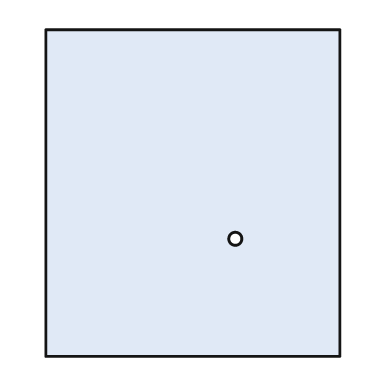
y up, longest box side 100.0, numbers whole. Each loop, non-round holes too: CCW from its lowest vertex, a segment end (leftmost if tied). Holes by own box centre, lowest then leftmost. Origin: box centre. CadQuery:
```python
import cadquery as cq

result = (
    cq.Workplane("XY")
    .moveTo(-45.0, -50.0)
    .lineTo(45.0, -50.0)
    .lineTo(45.0, 50.0)
    .lineTo(-45.0, 50.0)
    .close()
    .moveTo(13.0, -14.0)
    .circle(2.0)
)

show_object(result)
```